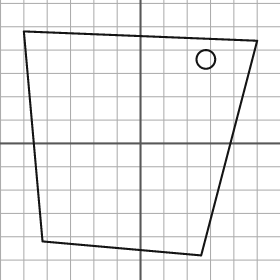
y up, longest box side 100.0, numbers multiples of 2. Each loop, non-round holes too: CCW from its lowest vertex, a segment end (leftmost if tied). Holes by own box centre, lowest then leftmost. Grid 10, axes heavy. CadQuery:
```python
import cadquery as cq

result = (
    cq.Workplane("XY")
    .moveTo(26.0, -48.0)
    .lineTo(50.0, 44.0)
    .lineTo(-50.0, 48.0)
    .lineTo(-42.0, -42.0)
    .close()
    .moveTo(28.0, 36.0)
    .circle(4.0)
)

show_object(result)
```